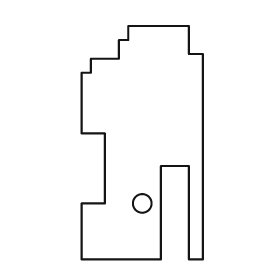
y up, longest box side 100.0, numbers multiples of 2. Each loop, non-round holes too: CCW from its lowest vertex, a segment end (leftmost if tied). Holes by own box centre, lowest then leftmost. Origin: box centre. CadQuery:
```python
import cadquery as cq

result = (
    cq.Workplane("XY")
    .moveTo(-26.0, -50.0)
    .lineTo(8.0, -50.0)
    .lineTo(8.0, -10.0)
    .lineTo(20.0, -10.0)
    .lineTo(20.0, -50.0)
    .lineTo(26.0, -50.0)
    .lineTo(26.0, 38.0)
    .lineTo(20.0, 38.0)
    .lineTo(20.0, 50.0)
    .lineTo(-6.0, 50.0)
    .lineTo(-6.0, 44.0)
    .lineTo(-10.0, 44.0)
    .lineTo(-10.0, 36.0)
    .lineTo(-22.0, 36.0)
    .lineTo(-22.0, 30.0)
    .lineTo(-26.0, 30.0)
    .lineTo(-26.0, 4.0)
    .lineTo(-16.0, 4.0)
    .lineTo(-16.0, -26.0)
    .lineTo(-26.0, -26.0)
    .close()
    .moveTo(0.0, -26.0)
    .circle(4.0)
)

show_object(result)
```